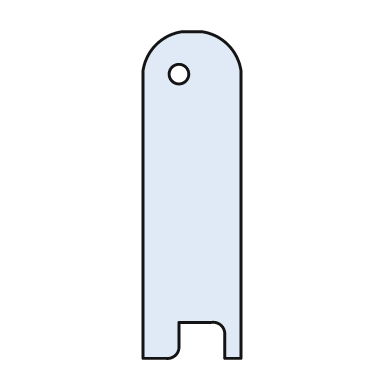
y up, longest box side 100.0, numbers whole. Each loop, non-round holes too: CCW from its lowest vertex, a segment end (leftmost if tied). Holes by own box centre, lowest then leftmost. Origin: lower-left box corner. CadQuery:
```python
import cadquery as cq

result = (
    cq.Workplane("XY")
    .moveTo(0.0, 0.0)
    .lineTo(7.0, 0.0)
    .threePointArc((10.0, 1.0), (11.0, 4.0))
    .lineTo(11.0, 11.0)
    .lineTo(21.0, 11.0)
    .threePointArc((24.0, 10.0), (25.0, 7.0))
    .lineTo(25.0, 0.0)
    .lineTo(30.0, 0.0)
    .lineTo(30.0, 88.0)
    .threePointArc((26.0, 96.0), (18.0, 100.0))
    .lineTo(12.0, 100.0)
    .threePointArc((4.0, 96.0), (0.0, 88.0))
    .close()
    .moveTo(11.0, 87.0)
    .circle(3.0)
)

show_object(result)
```